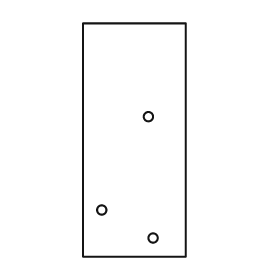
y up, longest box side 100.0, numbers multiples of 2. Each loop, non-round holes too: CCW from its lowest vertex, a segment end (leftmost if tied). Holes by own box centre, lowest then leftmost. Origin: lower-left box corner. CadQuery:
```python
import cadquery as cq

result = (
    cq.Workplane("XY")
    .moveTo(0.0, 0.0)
    .lineTo(44.0, 0.0)
    .lineTo(44.0, 100.0)
    .lineTo(0.0, 100.0)
    .close()
    .moveTo(30.0, 8.0)
    .circle(2.0)
    .moveTo(8.0, 20.0)
    .circle(2.0)
    .moveTo(28.0, 60.0)
    .circle(2.0)
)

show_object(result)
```